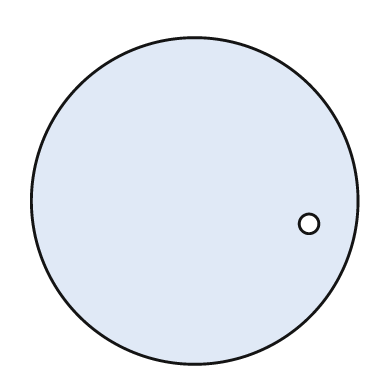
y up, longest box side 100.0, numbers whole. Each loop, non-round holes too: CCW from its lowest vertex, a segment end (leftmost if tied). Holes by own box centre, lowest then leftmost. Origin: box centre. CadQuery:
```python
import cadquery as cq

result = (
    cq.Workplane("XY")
    .moveTo(0.0, 0.0)
    .circle(50.0)
    .moveTo(35.0, -7.0)
    .circle(3.0)
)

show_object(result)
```